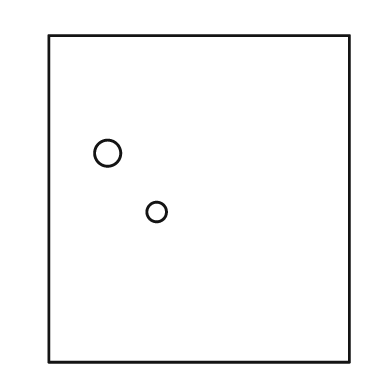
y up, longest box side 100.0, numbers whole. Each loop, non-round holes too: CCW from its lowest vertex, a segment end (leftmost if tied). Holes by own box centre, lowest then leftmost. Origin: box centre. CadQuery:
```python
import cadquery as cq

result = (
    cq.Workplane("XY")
    .moveTo(-46.0, -50.0)
    .lineTo(46.0, -50.0)
    .lineTo(46.0, 50.0)
    .lineTo(-46.0, 50.0)
    .close()
    .moveTo(-13.0, -4.0)
    .circle(3.0)
    .moveTo(-28.0, 14.0)
    .circle(4.0)
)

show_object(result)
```